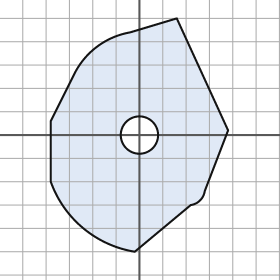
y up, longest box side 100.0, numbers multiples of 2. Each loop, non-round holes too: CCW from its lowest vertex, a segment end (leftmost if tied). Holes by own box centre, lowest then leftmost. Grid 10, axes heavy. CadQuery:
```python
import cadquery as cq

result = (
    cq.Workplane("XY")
    .moveTo(-2.0, -50.0)
    .lineTo(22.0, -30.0)
    .threePointArc((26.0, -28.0), (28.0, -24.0))
    .lineTo(38.0, 2.0)
    .lineTo(16.0, 50.0)
    .lineTo(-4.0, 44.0)
    .threePointArc((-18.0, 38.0), (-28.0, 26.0))
    .lineTo(-38.0, 6.0)
    .lineTo(-38.0, -20.0)
    .threePointArc((-24.0, -40.0), (-2.0, -50.0))
    .close()
    .moveTo(0.0, 0.0)
    .circle(8.0)
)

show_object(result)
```